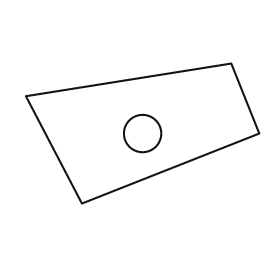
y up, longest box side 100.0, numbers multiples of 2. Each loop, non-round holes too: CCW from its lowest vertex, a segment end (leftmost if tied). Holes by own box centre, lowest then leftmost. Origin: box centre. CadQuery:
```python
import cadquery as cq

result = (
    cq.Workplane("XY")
    .moveTo(-26.0, -30.0)
    .lineTo(50.0, 0.0)
    .lineTo(38.0, 30.0)
    .lineTo(-50.0, 16.0)
    .close()
    .moveTo(0.0, 0.0)
    .circle(8.0)
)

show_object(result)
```